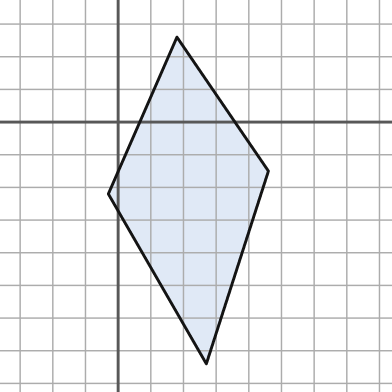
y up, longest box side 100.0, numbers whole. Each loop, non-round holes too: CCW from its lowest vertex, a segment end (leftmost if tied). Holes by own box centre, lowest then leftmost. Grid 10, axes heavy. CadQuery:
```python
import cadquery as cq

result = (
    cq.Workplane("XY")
    .moveTo(27.0, -74.0)
    .lineTo(46.0, -15.0)
    .lineTo(18.0, 26.0)
    .lineTo(-3.0, -22.0)
    .close()
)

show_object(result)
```